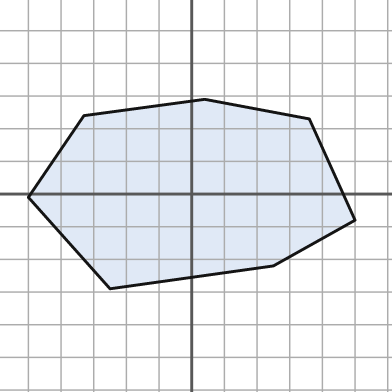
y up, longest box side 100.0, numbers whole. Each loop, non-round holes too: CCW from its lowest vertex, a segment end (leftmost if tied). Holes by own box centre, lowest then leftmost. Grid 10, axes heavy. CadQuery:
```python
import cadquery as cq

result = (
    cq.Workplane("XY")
    .moveTo(-25.0, -29.0)
    .lineTo(25.0, -22.0)
    .lineTo(50.0, -8.0)
    .lineTo(36.0, 23.0)
    .lineTo(4.0, 29.0)
    .lineTo(-33.0, 24.0)
    .lineTo(-50.0, -1.0)
    .close()
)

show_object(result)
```